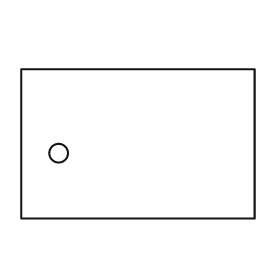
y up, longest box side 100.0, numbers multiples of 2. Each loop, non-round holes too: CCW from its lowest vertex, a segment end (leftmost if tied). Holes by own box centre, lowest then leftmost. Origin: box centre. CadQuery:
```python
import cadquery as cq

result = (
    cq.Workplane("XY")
    .moveTo(-50.0, -32.0)
    .lineTo(50.0, -32.0)
    .lineTo(50.0, 32.0)
    .lineTo(-50.0, 32.0)
    .close()
    .moveTo(-34.0, -4.0)
    .circle(4.0)
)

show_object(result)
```